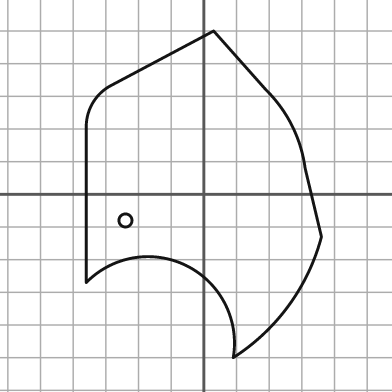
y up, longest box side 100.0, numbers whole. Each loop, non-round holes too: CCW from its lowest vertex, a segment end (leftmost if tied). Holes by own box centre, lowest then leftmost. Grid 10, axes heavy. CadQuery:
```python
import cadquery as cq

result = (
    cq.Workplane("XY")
    .moveTo(9.0, -50.0)
    .threePointArc((26.0, -34.0), (36.0, -13.0))
    .lineTo(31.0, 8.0)
    .threePointArc((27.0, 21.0), (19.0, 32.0))
    .lineTo(3.0, 50.0)
    .lineTo(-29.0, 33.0)
    .threePointArc((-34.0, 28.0), (-36.0, 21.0))
    .lineTo(-36.0, -27.0)
    .threePointArc((-5.0, -22.0), (9.0, -50.0))
    .close()
    .moveTo(-24.0, -8.0)
    .circle(2.0)
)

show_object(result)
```